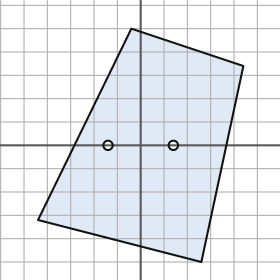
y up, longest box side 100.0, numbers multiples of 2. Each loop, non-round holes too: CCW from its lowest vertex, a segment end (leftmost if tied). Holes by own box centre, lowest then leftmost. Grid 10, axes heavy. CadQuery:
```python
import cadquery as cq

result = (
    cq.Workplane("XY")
    .moveTo(26.0, -50.0)
    .lineTo(44.0, 34.0)
    .lineTo(-4.0, 50.0)
    .lineTo(-44.0, -32.0)
    .close()
    .moveTo(-14.0, 0.0)
    .circle(2.0)
    .moveTo(14.0, 0.0)
    .circle(2.0)
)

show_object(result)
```